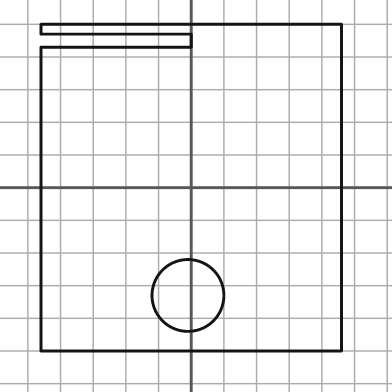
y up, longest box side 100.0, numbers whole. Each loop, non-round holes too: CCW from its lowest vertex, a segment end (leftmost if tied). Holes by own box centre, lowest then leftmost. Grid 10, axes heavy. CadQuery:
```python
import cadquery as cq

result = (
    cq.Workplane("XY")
    .moveTo(-46.0, -50.0)
    .lineTo(46.0, -50.0)
    .lineTo(46.0, 50.0)
    .lineTo(-46.0, 50.0)
    .lineTo(-46.0, 47.0)
    .lineTo(0.0, 47.0)
    .lineTo(0.0, 43.0)
    .lineTo(-46.0, 43.0)
    .close()
    .moveTo(-1.0, -33.0)
    .circle(11.0)
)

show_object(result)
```